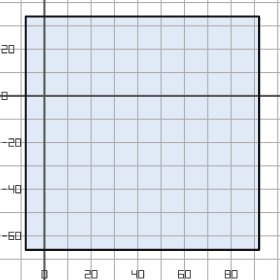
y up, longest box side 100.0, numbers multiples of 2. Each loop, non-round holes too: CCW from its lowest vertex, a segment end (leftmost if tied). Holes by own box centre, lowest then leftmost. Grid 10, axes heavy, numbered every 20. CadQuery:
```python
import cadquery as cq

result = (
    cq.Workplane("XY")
    .moveTo(-8.0, -66.0)
    .lineTo(92.0, -66.0)
    .lineTo(92.0, 34.0)
    .lineTo(-8.0, 34.0)
    .close()
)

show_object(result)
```